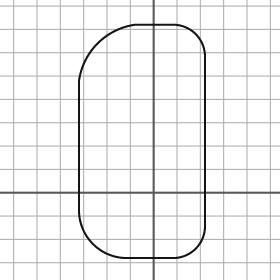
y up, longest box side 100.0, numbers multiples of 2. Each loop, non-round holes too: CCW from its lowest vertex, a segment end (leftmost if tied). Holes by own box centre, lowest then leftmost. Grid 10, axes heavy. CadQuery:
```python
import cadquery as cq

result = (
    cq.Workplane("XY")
    .moveTo(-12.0, -28.0)
    .lineTo(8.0, -28.0)
    .threePointArc((18.0, -24.0), (22.0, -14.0))
    .lineTo(22.0, 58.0)
    .threePointArc((18.0, 68.0), (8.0, 72.0))
    .lineTo(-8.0, 72.0)
    .threePointArc((-24.0, 64.0), (-32.0, 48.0))
    .lineTo(-32.0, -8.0)
    .threePointArc((-26.0, -22.0), (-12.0, -28.0))
    .close()
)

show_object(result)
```